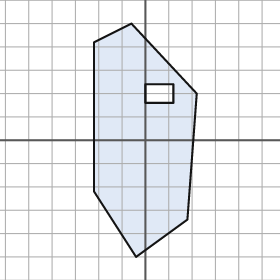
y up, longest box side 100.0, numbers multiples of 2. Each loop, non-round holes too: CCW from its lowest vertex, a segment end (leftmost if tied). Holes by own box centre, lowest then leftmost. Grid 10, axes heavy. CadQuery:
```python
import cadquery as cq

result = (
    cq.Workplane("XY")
    .moveTo(-4.0, -50.0)
    .lineTo(18.0, -34.0)
    .lineTo(22.0, 20.0)
    .lineTo(-6.0, 50.0)
    .lineTo(-22.0, 42.0)
    .lineTo(-22.0, -22.0)
    .close()
    .moveTo(0.0, 16.0)
    .lineTo(12.0, 16.0)
    .lineTo(12.0, 24.0)
    .lineTo(0.0, 24.0)
    .close()
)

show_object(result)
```